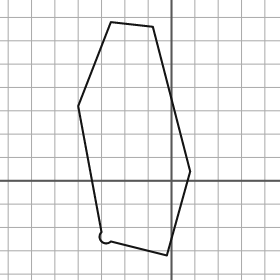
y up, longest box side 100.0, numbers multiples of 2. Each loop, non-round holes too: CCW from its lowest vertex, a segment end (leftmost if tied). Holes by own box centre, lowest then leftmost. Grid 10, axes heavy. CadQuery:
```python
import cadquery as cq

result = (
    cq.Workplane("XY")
    .moveTo(-2.0, -32.0)
    .lineTo(8.0, 4.0)
    .lineTo(-8.0, 66.0)
    .lineTo(-26.0, 68.0)
    .lineTo(-40.0, 32.0)
    .lineTo(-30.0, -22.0)
    .threePointArc((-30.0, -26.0), (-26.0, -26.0))
    .close()
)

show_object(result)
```